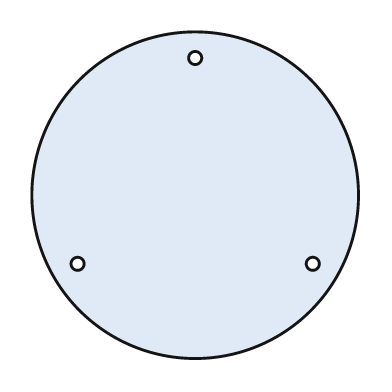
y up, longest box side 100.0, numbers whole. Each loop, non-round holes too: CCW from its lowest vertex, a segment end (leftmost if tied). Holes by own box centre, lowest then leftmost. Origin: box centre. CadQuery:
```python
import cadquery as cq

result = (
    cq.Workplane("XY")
    .moveTo(0.0, 0.0)
    .circle(50.0)
    .moveTo(-36.0, -21.0)
    .circle(2.0)
    .moveTo(36.0, -21.0)
    .circle(2.0)
    .moveTo(0.0, 42.0)
    .circle(2.0)
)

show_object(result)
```